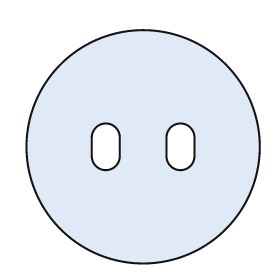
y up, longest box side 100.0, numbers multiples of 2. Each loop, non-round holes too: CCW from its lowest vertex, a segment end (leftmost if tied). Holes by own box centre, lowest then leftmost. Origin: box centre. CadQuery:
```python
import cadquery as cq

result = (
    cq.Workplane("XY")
    .moveTo(0.0, 0.0)
    .circle(50.0)
    .moveTo(-22.0, -4.0)
    .threePointArc((-16.0, -10.0), (-10.0, -4.0))
    .lineTo(-10.0, 4.0)
    .threePointArc((-16.0, 10.0), (-22.0, 4.0))
    .close()
    .moveTo(10.0, -4.0)
    .threePointArc((16.0, -10.0), (22.0, -4.0))
    .lineTo(22.0, 4.0)
    .threePointArc((16.0, 10.0), (10.0, 4.0))
    .close()
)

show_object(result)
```